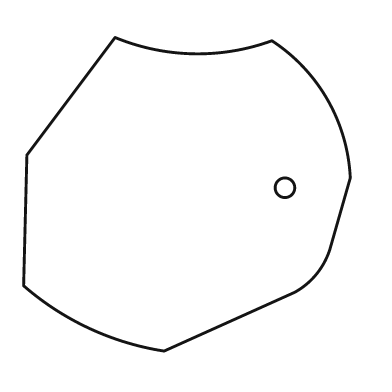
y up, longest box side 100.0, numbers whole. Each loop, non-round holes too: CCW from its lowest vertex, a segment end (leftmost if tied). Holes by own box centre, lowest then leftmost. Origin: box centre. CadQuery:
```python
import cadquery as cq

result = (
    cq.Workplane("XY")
    .moveTo(-7.0, -48.0)
    .lineTo(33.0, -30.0)
    .threePointArc((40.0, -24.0), (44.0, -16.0))
    .lineTo(50.0, 5.0)
    .threePointArc((43.0, 29.0), (26.0, 47.0))
    .threePointArc((2.0, 43.0), (-22.0, 48.0))
    .lineTo(-49.0, 12.0)
    .lineTo(-50.0, -28.0)
    .threePointArc((-30.0, -41.0), (-7.0, -48.0))
    .close()
    .moveTo(30.0, 2.0)
    .circle(3.0)
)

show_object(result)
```